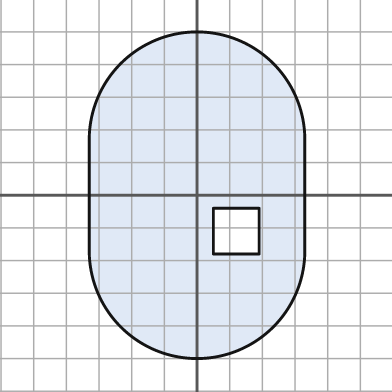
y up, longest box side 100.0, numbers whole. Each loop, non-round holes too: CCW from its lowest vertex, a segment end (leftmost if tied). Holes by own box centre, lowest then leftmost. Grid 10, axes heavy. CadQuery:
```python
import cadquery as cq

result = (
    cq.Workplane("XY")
    .moveTo(-33.0, -17.0)
    .threePointArc((0.0, -50.0), (33.0, -17.0))
    .lineTo(33.0, 17.0)
    .threePointArc((0.0, 50.0), (-33.0, 17.0))
    .close()
    .moveTo(5.0, -18.0)
    .lineTo(19.0, -18.0)
    .lineTo(19.0, -4.0)
    .lineTo(5.0, -4.0)
    .close()
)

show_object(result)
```